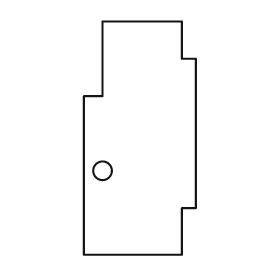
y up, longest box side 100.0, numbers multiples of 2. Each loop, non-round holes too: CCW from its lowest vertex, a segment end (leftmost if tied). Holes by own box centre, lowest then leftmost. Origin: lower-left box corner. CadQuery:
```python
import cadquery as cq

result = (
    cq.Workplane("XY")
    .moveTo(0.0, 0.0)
    .lineTo(42.0, 0.0)
    .lineTo(42.0, 20.0)
    .lineTo(48.0, 20.0)
    .lineTo(48.0, 84.0)
    .lineTo(42.0, 84.0)
    .lineTo(42.0, 100.0)
    .lineTo(8.0, 100.0)
    .lineTo(8.0, 68.0)
    .lineTo(0.0, 68.0)
    .close()
    .moveTo(8.0, 36.0)
    .circle(4.0)
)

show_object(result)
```